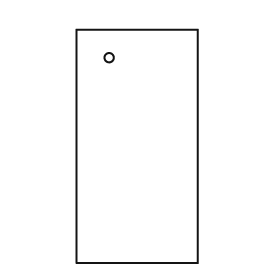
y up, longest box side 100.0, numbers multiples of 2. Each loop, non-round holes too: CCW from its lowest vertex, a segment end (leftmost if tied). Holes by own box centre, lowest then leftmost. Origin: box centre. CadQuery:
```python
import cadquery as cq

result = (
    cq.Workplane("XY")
    .moveTo(-26.0, -50.0)
    .lineTo(26.0, -50.0)
    .lineTo(26.0, 50.0)
    .lineTo(-26.0, 50.0)
    .close()
    .moveTo(-12.0, 38.0)
    .circle(2.0)
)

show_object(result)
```